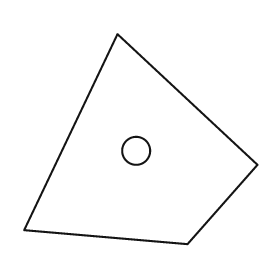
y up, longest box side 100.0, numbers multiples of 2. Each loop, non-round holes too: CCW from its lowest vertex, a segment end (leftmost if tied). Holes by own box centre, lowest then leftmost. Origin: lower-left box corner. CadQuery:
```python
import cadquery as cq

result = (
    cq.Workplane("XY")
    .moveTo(70.0, 0.0)
    .lineTo(100.0, 34.0)
    .lineTo(40.0, 90.0)
    .lineTo(0.0, 6.0)
    .close()
    .moveTo(48.0, 40.0)
    .circle(6.0)
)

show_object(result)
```